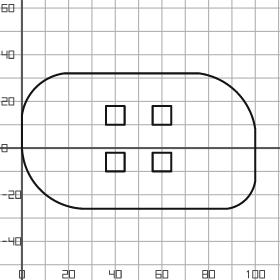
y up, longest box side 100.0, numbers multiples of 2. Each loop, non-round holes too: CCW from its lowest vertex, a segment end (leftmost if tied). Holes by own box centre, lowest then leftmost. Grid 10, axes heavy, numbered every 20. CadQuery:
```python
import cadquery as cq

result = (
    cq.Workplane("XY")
    .moveTo(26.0, -26.0)
    .lineTo(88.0, -26.0)
    .threePointArc((96.0, -22.0), (100.0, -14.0))
    .lineTo(100.0, 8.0)
    .threePointArc((92.0, 24.0), (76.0, 32.0))
    .lineTo(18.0, 32.0)
    .threePointArc((6.0, 26.0), (0.0, 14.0))
    .lineTo(0.0, 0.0)
    .threePointArc((8.0, -18.0), (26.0, -26.0))
    .close()
    .moveTo(36.0, -10.0)
    .lineTo(44.0, -10.0)
    .lineTo(44.0, -2.0)
    .lineTo(36.0, -2.0)
    .close()
    .moveTo(56.0, -10.0)
    .lineTo(64.0, -10.0)
    .lineTo(64.0, -2.0)
    .lineTo(56.0, -2.0)
    .close()
    .moveTo(36.0, 10.0)
    .lineTo(44.0, 10.0)
    .lineTo(44.0, 18.0)
    .lineTo(36.0, 18.0)
    .close()
    .moveTo(56.0, 10.0)
    .lineTo(64.0, 10.0)
    .lineTo(64.0, 18.0)
    .lineTo(56.0, 18.0)
    .close()
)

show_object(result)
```